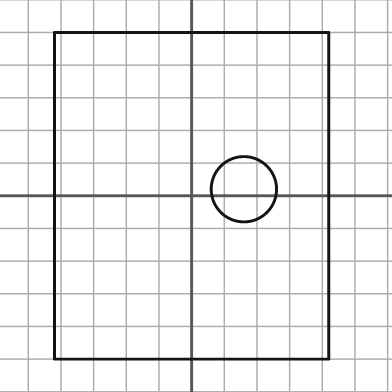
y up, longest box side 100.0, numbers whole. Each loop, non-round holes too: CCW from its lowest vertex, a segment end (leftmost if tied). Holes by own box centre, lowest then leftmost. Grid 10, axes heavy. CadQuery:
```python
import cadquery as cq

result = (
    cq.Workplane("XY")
    .moveTo(-42.0, -50.0)
    .lineTo(42.0, -50.0)
    .lineTo(42.0, 50.0)
    .lineTo(-42.0, 50.0)
    .close()
    .moveTo(16.0, 2.0)
    .circle(10.0)
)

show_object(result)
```